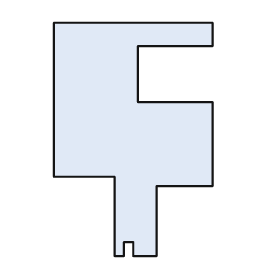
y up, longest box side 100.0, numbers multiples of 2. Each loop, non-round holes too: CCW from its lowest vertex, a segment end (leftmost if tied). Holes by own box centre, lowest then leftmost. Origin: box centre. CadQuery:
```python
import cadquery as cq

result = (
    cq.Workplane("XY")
    .moveTo(-8.0, -50.0)
    .lineTo(-4.0, -50.0)
    .lineTo(-4.0, -44.0)
    .lineTo(0.0, -44.0)
    .lineTo(0.0, -50.0)
    .lineTo(10.0, -50.0)
    .lineTo(10.0, -20.0)
    .lineTo(34.0, -20.0)
    .lineTo(34.0, 16.0)
    .lineTo(2.0, 16.0)
    .lineTo(2.0, 40.0)
    .lineTo(34.0, 40.0)
    .lineTo(34.0, 50.0)
    .lineTo(-34.0, 50.0)
    .lineTo(-34.0, -16.0)
    .lineTo(-8.0, -16.0)
    .close()
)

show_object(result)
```